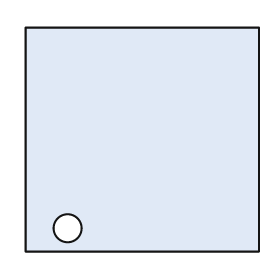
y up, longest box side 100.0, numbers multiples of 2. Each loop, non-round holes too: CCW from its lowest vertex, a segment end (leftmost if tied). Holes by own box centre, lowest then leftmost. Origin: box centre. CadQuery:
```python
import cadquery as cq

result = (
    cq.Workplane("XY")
    .moveTo(-50.0, -48.0)
    .lineTo(50.0, -48.0)
    .lineTo(50.0, 48.0)
    .lineTo(-50.0, 48.0)
    .close()
    .moveTo(-32.0, -38.0)
    .circle(6.0)
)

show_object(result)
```